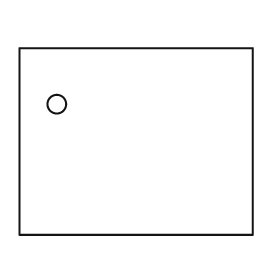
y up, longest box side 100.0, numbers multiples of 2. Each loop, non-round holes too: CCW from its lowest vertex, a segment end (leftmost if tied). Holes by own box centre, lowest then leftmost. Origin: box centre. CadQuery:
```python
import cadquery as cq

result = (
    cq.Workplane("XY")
    .moveTo(-50.0, -40.0)
    .lineTo(50.0, -40.0)
    .lineTo(50.0, 40.0)
    .lineTo(-50.0, 40.0)
    .close()
    .moveTo(-34.0, 16.0)
    .circle(4.0)
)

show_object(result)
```